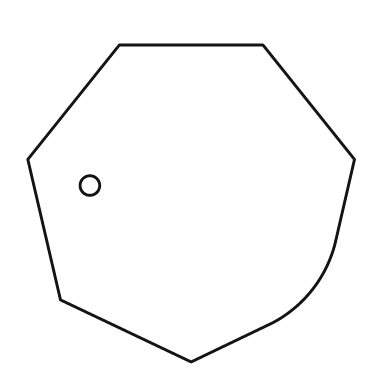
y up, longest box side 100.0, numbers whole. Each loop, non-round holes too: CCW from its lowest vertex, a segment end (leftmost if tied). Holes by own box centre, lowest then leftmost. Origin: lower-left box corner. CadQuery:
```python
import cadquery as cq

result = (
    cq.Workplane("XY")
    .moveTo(50.0, 0.0)
    .lineTo(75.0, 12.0)
    .threePointArc((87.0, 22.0), (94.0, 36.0))
    .lineTo(100.0, 62.0)
    .lineTo(72.0, 97.0)
    .lineTo(28.0, 97.0)
    .lineTo(0.0, 62.0)
    .lineTo(10.0, 19.0)
    .close()
    .moveTo(19.0, 54.0)
    .circle(3.0)
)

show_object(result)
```